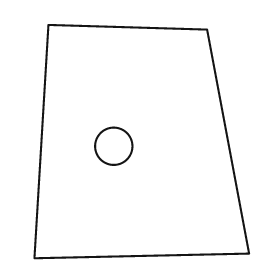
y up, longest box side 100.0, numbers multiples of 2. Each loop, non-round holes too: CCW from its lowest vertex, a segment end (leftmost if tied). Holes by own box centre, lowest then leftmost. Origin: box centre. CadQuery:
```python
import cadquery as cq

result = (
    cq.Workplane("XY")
    .moveTo(-46.0, -50.0)
    .lineTo(46.0, -48.0)
    .lineTo(28.0, 48.0)
    .lineTo(-40.0, 50.0)
    .close()
    .moveTo(-12.0, -2.0)
    .circle(8.0)
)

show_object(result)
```